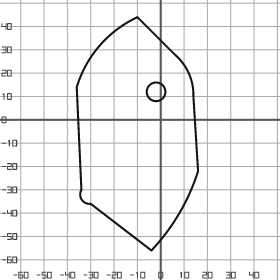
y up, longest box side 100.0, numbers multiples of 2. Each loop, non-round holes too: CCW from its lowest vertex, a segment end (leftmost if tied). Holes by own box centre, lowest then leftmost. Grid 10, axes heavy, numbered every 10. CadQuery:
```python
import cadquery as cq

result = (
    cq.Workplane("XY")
    .moveTo(-4.0, -56.0)
    .threePointArc((8.0, -40.0), (16.0, -22.0))
    .lineTo(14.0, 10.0)
    .threePointArc((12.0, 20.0), (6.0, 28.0))
    .lineTo(-10.0, 44.0)
    .threePointArc((-26.0, 32.0), (-36.0, 14.0))
    .lineTo(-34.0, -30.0)
    .threePointArc((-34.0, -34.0), (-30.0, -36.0))
    .close()
    .moveTo(-2.0, 12.0)
    .circle(4.0)
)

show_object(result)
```